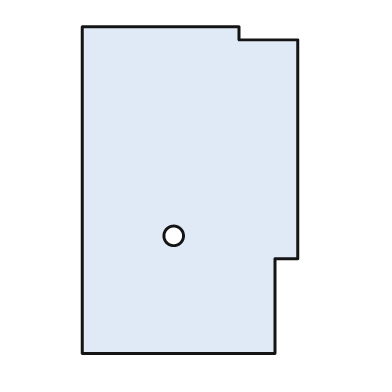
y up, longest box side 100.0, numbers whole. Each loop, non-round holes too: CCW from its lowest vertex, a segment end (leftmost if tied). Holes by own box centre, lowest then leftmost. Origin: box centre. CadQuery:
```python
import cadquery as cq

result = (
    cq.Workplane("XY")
    .moveTo(-33.0, -50.0)
    .lineTo(26.0, -50.0)
    .lineTo(26.0, -21.0)
    .lineTo(33.0, -21.0)
    .lineTo(33.0, 46.0)
    .lineTo(15.0, 46.0)
    .lineTo(15.0, 50.0)
    .lineTo(-33.0, 50.0)
    .close()
    .moveTo(-5.0, -14.0)
    .circle(3.0)
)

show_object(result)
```